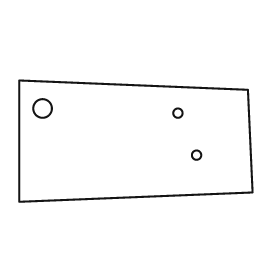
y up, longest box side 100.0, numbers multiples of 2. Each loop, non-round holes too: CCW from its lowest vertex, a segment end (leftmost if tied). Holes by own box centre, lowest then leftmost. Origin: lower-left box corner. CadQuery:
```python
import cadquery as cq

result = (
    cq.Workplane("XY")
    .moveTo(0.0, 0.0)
    .lineTo(100.0, 4.0)
    .lineTo(98.0, 48.0)
    .lineTo(0.0, 52.0)
    .close()
    .moveTo(76.0, 20.0)
    .circle(2.0)
    .moveTo(68.0, 38.0)
    .circle(2.0)
    .moveTo(10.0, 40.0)
    .circle(4.0)
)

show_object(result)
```